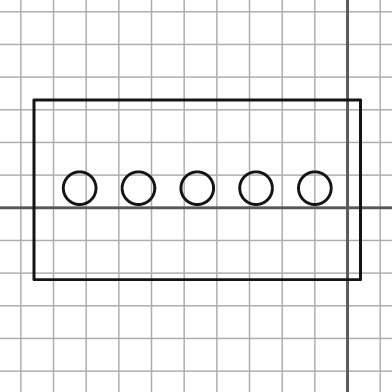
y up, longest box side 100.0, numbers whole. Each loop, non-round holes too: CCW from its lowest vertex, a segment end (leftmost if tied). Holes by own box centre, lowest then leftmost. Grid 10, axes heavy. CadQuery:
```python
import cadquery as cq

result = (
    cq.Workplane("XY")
    .moveTo(-96.0, -22.0)
    .lineTo(4.0, -22.0)
    .lineTo(4.0, 33.0)
    .lineTo(-96.0, 33.0)
    .close()
    .moveTo(-82.0, 6.0)
    .circle(5.0)
    .moveTo(-64.0, 6.0)
    .circle(5.0)
    .moveTo(-46.0, 6.0)
    .circle(5.0)
    .moveTo(-28.0, 6.0)
    .circle(5.0)
    .moveTo(-10.0, 6.0)
    .circle(5.0)
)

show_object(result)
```